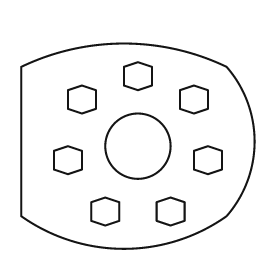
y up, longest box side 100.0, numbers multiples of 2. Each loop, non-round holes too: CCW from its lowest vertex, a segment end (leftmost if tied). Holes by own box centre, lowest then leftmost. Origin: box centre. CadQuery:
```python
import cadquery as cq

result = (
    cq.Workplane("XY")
    .moveTo(-50.0, -30.0)
    .threePointArc((-6.0, -44.0), (38.0, -30.0))
    .threePointArc((50.0, 2.0), (38.0, 34.0))
    .threePointArc((-6.0, 44.0), (-50.0, 34.0))
    .close()
    .moveTo(-14.0, -34.0)
    .lineTo(-8.0, -32.0)
    .lineTo(-8.0, -24.0)
    .lineTo(-14.0, -22.0)
    .lineTo(-20.0, -24.0)
    .lineTo(-20.0, -32.0)
    .close()
    .moveTo(14.0, -34.0)
    .lineTo(20.0, -32.0)
    .lineTo(20.0, -24.0)
    .lineTo(14.0, -22.0)
    .lineTo(8.0, -24.0)
    .lineTo(8.0, -32.0)
    .close()
    .moveTo(-30.0, -12.0)
    .lineTo(-24.0, -10.0)
    .lineTo(-24.0, -2.0)
    .lineTo(-30.0, 0.0)
    .lineTo(-36.0, -2.0)
    .lineTo(-36.0, -10.0)
    .close()
    .moveTo(30.0, -12.0)
    .lineTo(36.0, -10.0)
    .lineTo(36.0, -2.0)
    .lineTo(30.0, 0.0)
    .lineTo(24.0, -2.0)
    .lineTo(24.0, -10.0)
    .close()
    .moveTo(0.0, 0.0)
    .circle(14.0)
    .moveTo(-24.0, 14.0)
    .lineTo(-18.0, 16.0)
    .lineTo(-18.0, 24.0)
    .lineTo(-24.0, 26.0)
    .lineTo(-30.0, 24.0)
    .lineTo(-30.0, 16.0)
    .close()
    .moveTo(24.0, 14.0)
    .lineTo(30.0, 16.0)
    .lineTo(30.0, 24.0)
    .lineTo(24.0, 26.0)
    .lineTo(18.0, 24.0)
    .lineTo(18.0, 16.0)
    .close()
    .moveTo(0.0, 24.0)
    .lineTo(6.0, 26.0)
    .lineTo(6.0, 34.0)
    .lineTo(0.0, 36.0)
    .lineTo(-6.0, 34.0)
    .lineTo(-6.0, 26.0)
    .close()
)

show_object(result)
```